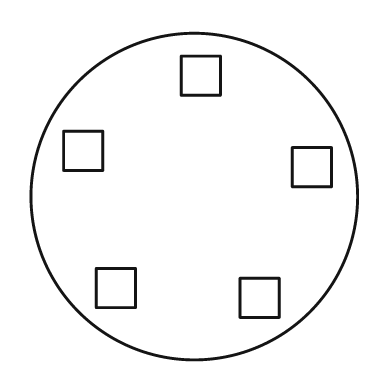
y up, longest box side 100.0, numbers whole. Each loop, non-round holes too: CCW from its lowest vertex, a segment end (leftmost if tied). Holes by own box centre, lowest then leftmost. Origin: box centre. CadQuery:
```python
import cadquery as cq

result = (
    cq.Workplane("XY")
    .moveTo(0.0, 0.0)
    .circle(50.0)
    .moveTo(14.0, -37.0)
    .lineTo(26.0, -37.0)
    .lineTo(26.0, -25.0)
    .lineTo(14.0, -25.0)
    .close()
    .moveTo(-30.0, -34.0)
    .lineTo(-18.0, -34.0)
    .lineTo(-18.0, -22.0)
    .lineTo(-30.0, -22.0)
    .close()
    .moveTo(30.0, 3.0)
    .lineTo(42.0, 3.0)
    .lineTo(42.0, 15.0)
    .lineTo(30.0, 15.0)
    .close()
    .moveTo(-40.0, 8.0)
    .lineTo(-28.0, 8.0)
    .lineTo(-28.0, 20.0)
    .lineTo(-40.0, 20.0)
    .close()
    .moveTo(-4.0, 31.0)
    .lineTo(8.0, 31.0)
    .lineTo(8.0, 43.0)
    .lineTo(-4.0, 43.0)
    .close()
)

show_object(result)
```